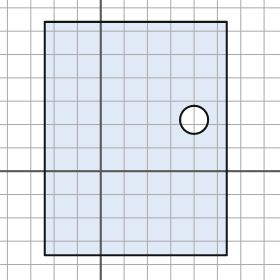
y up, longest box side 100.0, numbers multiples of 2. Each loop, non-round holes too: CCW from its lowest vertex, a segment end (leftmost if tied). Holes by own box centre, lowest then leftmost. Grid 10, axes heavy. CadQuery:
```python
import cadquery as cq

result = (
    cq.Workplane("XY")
    .moveTo(-24.0, -36.0)
    .lineTo(54.0, -36.0)
    .lineTo(54.0, 64.0)
    .lineTo(-24.0, 64.0)
    .close()
    .moveTo(40.0, 22.0)
    .circle(6.0)
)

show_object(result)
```